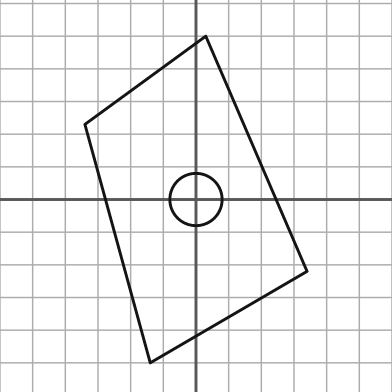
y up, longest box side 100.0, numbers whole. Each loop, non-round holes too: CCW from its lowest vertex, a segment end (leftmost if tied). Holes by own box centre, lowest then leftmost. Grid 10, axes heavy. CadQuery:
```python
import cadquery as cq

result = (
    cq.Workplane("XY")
    .moveTo(-14.0, -50.0)
    .lineTo(34.0, -22.0)
    .lineTo(3.0, 50.0)
    .lineTo(-34.0, 23.0)
    .close()
    .moveTo(0.0, 0.0)
    .circle(8.0)
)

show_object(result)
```